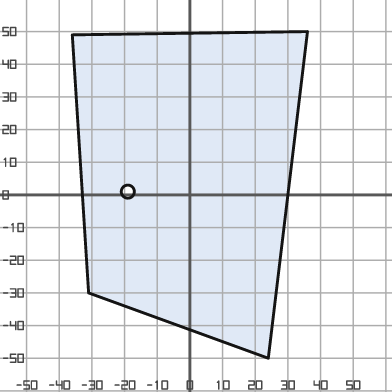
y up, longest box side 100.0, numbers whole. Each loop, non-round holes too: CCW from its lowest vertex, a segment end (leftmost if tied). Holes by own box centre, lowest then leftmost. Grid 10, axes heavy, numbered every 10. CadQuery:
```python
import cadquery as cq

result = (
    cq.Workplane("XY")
    .moveTo(24.0, -50.0)
    .lineTo(36.0, 50.0)
    .lineTo(-36.0, 49.0)
    .lineTo(-31.0, -30.0)
    .close()
    .moveTo(-19.0, 1.0)
    .circle(2.0)
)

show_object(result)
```